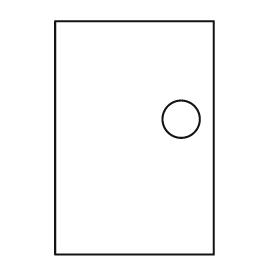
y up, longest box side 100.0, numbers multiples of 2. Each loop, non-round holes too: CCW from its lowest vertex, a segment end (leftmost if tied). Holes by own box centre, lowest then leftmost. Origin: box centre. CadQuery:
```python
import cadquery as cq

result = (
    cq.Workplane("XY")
    .moveTo(-34.0, -50.0)
    .lineTo(34.0, -50.0)
    .lineTo(34.0, 50.0)
    .lineTo(-34.0, 50.0)
    .close()
    .moveTo(20.0, 8.0)
    .circle(8.0)
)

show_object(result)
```